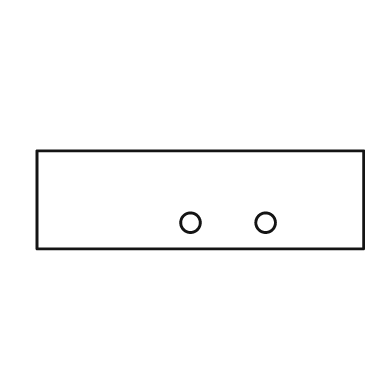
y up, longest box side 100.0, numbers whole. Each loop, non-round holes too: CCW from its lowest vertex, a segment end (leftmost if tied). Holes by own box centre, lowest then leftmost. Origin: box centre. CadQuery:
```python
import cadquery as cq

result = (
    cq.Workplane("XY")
    .moveTo(-50.0, -15.0)
    .lineTo(50.0, -15.0)
    .lineTo(50.0, 15.0)
    .lineTo(-50.0, 15.0)
    .close()
    .moveTo(-3.0, -7.0)
    .circle(3.0)
    .moveTo(20.0, -7.0)
    .circle(3.0)
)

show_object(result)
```